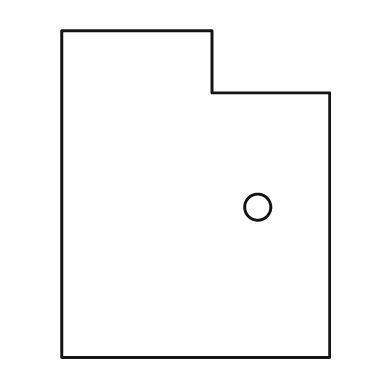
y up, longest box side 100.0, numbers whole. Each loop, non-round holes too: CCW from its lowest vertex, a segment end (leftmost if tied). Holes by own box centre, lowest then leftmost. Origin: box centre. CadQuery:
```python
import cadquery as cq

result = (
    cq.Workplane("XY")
    .moveTo(-41.0, -50.0)
    .lineTo(41.0, -50.0)
    .lineTo(41.0, 31.0)
    .lineTo(5.0, 31.0)
    .lineTo(5.0, 50.0)
    .lineTo(-41.0, 50.0)
    .close()
    .moveTo(19.0, -4.0)
    .circle(4.0)
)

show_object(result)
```